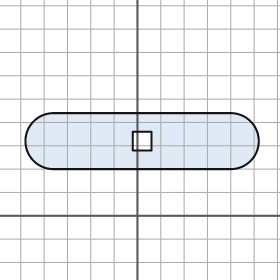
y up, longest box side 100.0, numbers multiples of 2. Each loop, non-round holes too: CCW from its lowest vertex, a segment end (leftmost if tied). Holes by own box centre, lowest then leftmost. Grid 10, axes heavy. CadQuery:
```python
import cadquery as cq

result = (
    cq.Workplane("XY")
    .moveTo(-36.0, 20.0)
    .lineTo(40.0, 20.0)
    .threePointArc((52.0, 32.0), (40.0, 44.0))
    .lineTo(-36.0, 44.0)
    .threePointArc((-48.0, 32.0), (-36.0, 20.0))
    .close()
    .moveTo(-2.0, 28.0)
    .lineTo(6.0, 28.0)
    .lineTo(6.0, 36.0)
    .lineTo(-2.0, 36.0)
    .close()
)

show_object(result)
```